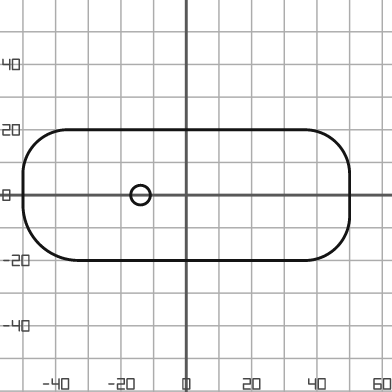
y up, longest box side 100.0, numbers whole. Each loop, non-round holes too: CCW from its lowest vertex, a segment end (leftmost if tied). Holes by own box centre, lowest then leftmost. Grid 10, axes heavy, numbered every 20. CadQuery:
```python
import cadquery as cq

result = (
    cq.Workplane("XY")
    .moveTo(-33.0, -20.0)
    .lineTo(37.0, -20.0)
    .threePointArc((46.0, -16.0), (50.0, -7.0))
    .lineTo(50.0, 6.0)
    .threePointArc((46.0, 16.0), (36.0, 20.0))
    .lineTo(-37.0, 20.0)
    .threePointArc((-46.0, 16.0), (-50.0, 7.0))
    .lineTo(-50.0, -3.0)
    .threePointArc((-45.0, -15.0), (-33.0, -20.0))
    .close()
    .moveTo(-14.0, 0.0)
    .circle(3.0)
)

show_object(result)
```